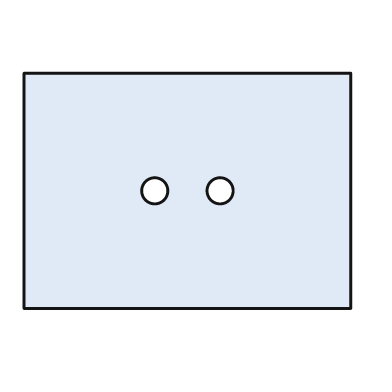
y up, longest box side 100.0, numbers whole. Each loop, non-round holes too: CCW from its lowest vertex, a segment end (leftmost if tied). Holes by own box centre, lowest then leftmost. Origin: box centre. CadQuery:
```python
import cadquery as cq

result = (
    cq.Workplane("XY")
    .moveTo(-50.0, -36.0)
    .lineTo(50.0, -36.0)
    .lineTo(50.0, 36.0)
    .lineTo(-50.0, 36.0)
    .close()
    .moveTo(-10.0, 0.0)
    .circle(4.0)
    .moveTo(10.0, 0.0)
    .circle(4.0)
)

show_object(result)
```